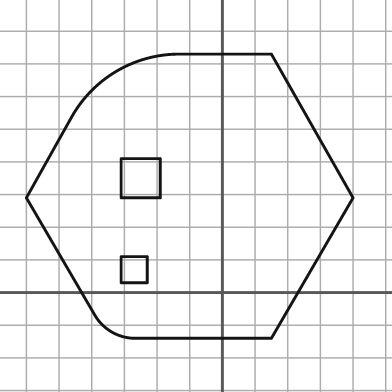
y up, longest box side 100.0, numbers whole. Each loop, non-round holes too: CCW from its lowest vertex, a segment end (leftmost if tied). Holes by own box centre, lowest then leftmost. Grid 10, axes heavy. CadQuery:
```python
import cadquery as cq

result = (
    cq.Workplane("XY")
    .moveTo(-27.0, -14.0)
    .lineTo(15.0, -14.0)
    .lineTo(40.0, 29.0)
    .lineTo(15.0, 73.0)
    .lineTo(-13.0, 73.0)
    .threePointArc((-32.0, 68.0), (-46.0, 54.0))
    .lineTo(-60.0, 29.0)
    .lineTo(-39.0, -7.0)
    .threePointArc((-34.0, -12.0), (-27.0, -14.0))
    .close()
    .moveTo(-31.0, 3.0)
    .lineTo(-23.0, 3.0)
    .lineTo(-23.0, 11.0)
    .lineTo(-31.0, 11.0)
    .close()
    .moveTo(-31.0, 29.0)
    .lineTo(-19.0, 29.0)
    .lineTo(-19.0, 41.0)
    .lineTo(-31.0, 41.0)
    .close()
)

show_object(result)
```